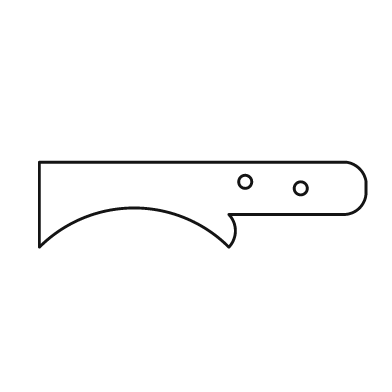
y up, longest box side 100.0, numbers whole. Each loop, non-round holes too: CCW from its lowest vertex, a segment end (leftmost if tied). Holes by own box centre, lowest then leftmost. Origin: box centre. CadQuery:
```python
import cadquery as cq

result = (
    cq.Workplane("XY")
    .moveTo(-50.0, -13.0)
    .threePointArc((-21.0, -1.0), (8.0, -13.0))
    .threePointArc((10.0, -8.0), (8.0, -3.0))
    .lineTo(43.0, -3.0)
    .threePointArc((48.0, -1.0), (50.0, 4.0))
    .lineTo(50.0, 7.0)
    .threePointArc((48.0, 11.0), (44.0, 13.0))
    .lineTo(-50.0, 13.0)
    .close()
    .moveTo(30.0, 5.0)
    .circle(2.0)
    .moveTo(13.0, 7.0)
    .circle(2.0)
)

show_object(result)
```